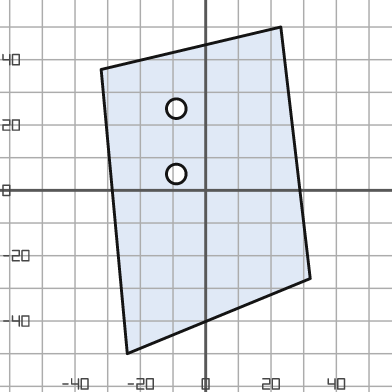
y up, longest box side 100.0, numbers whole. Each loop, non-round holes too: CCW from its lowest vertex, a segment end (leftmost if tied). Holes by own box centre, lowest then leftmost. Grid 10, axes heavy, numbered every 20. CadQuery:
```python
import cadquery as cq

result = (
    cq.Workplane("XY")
    .moveTo(-24.0, -50.0)
    .lineTo(32.0, -27.0)
    .lineTo(23.0, 50.0)
    .lineTo(-32.0, 37.0)
    .close()
    .moveTo(-9.0, 5.0)
    .circle(3.0)
    .moveTo(-9.0, 25.0)
    .circle(3.0)
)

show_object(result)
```